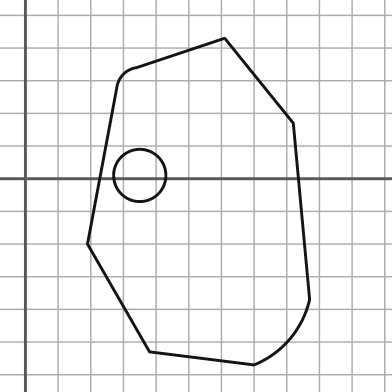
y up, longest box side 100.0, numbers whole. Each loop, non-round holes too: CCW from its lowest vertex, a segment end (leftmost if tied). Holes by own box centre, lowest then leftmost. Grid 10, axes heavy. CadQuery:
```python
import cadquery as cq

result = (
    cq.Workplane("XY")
    .moveTo(70.0, -57.0)
    .threePointArc((81.0, -49.0), (87.0, -37.0))
    .lineTo(82.0, 17.0)
    .lineTo(61.0, 43.0)
    .lineTo(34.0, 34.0)
    .threePointArc((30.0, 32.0), (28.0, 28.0))
    .lineTo(19.0, -20.0)
    .lineTo(38.0, -53.0)
    .close()
    .moveTo(35.0, 1.0)
    .circle(8.0)
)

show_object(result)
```